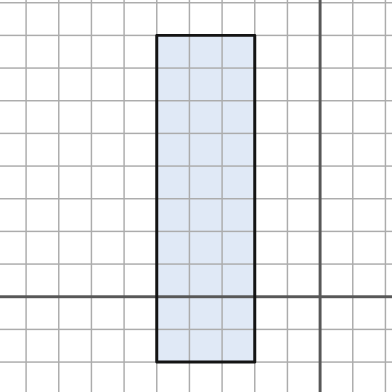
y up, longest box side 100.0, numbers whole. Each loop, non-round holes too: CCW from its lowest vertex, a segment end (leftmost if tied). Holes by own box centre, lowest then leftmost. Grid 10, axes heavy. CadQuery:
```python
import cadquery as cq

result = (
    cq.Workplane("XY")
    .moveTo(-50.0, -20.0)
    .lineTo(-20.0, -20.0)
    .lineTo(-20.0, 80.0)
    .lineTo(-50.0, 80.0)
    .close()
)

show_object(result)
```